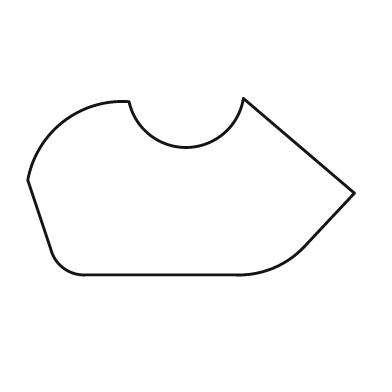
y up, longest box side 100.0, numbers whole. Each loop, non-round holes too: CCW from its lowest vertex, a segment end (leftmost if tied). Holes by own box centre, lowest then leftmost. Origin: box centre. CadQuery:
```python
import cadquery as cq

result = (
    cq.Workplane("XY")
    .moveTo(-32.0, -27.0)
    .lineTo(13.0, -27.0)
    .threePointArc((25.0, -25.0), (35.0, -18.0))
    .lineTo(50.0, -2.0)
    .lineTo(16.0, 27.0)
    .threePointArc((-1.0, 12.0), (-19.0, 26.0))
    .threePointArc((-39.0, 20.0), (-50.0, 2.0))
    .lineTo(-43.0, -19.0)
    .threePointArc((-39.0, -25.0), (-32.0, -27.0))
    .close()
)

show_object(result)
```